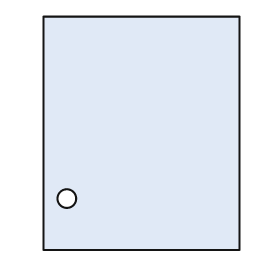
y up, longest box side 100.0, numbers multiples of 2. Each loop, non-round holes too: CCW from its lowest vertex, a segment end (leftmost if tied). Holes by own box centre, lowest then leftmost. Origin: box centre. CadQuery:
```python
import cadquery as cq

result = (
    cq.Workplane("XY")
    .moveTo(-42.0, -50.0)
    .lineTo(42.0, -50.0)
    .lineTo(42.0, 50.0)
    .lineTo(-42.0, 50.0)
    .close()
    .moveTo(-32.0, -28.0)
    .circle(4.0)
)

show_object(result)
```